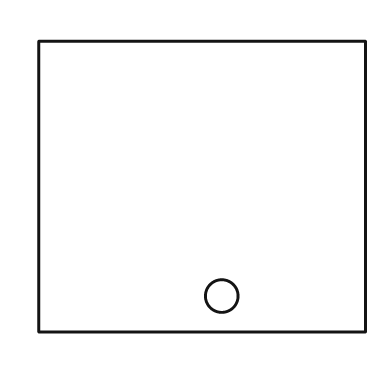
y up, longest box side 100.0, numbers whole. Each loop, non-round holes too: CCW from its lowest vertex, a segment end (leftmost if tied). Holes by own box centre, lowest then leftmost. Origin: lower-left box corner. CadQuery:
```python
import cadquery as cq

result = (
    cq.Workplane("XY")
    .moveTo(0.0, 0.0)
    .lineTo(100.0, 0.0)
    .lineTo(100.0, 89.0)
    .lineTo(0.0, 89.0)
    .close()
    .moveTo(56.0, 11.0)
    .circle(5.0)
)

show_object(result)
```